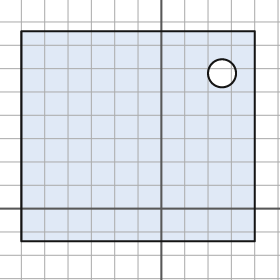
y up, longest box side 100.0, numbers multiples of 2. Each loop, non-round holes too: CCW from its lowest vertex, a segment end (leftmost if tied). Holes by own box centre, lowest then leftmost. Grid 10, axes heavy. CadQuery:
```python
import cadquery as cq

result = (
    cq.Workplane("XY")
    .moveTo(-60.0, -14.0)
    .lineTo(40.0, -14.0)
    .lineTo(40.0, 76.0)
    .lineTo(-60.0, 76.0)
    .close()
    .moveTo(26.0, 58.0)
    .circle(6.0)
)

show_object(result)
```